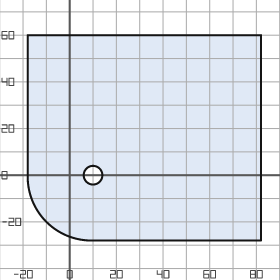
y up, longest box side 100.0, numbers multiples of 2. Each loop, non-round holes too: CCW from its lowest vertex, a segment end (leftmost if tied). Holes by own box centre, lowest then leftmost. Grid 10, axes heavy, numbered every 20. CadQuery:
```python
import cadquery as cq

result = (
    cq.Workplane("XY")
    .moveTo(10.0, -28.0)
    .lineTo(82.0, -28.0)
    .lineTo(82.0, 60.0)
    .lineTo(-18.0, 60.0)
    .lineTo(-18.0, 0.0)
    .threePointArc((-10.0, -20.0), (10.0, -28.0))
    .close()
    .moveTo(10.0, 0.0)
    .circle(4.0)
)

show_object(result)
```